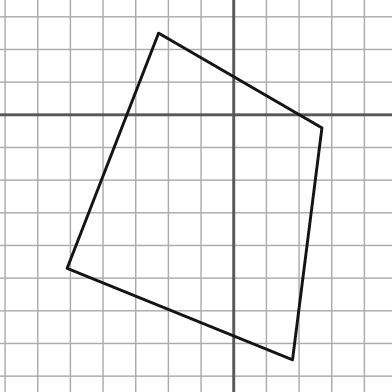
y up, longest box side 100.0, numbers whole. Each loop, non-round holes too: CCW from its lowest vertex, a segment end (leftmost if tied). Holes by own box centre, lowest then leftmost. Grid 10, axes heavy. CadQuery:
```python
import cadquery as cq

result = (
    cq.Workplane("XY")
    .moveTo(18.0, -75.0)
    .lineTo(27.0, -4.0)
    .lineTo(-23.0, 25.0)
    .lineTo(-51.0, -47.0)
    .close()
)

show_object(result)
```